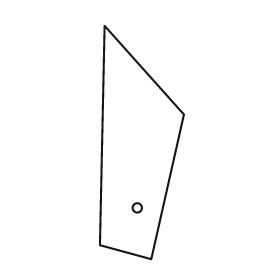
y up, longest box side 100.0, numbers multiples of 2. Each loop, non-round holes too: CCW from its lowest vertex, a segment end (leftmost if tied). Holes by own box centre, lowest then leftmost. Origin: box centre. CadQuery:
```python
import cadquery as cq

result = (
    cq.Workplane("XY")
    .moveTo(4.0, -50.0)
    .lineTo(18.0, 12.0)
    .lineTo(-16.0, 50.0)
    .lineTo(-18.0, -44.0)
    .close()
    .moveTo(-2.0, -28.0)
    .circle(2.0)
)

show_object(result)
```